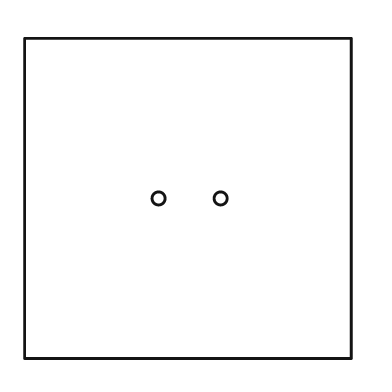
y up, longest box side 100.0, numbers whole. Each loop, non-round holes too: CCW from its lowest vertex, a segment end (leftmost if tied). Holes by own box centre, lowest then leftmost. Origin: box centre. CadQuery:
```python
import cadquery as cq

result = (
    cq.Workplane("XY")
    .moveTo(-50.0, -49.0)
    .lineTo(50.0, -49.0)
    .lineTo(50.0, 49.0)
    .lineTo(-50.0, 49.0)
    .close()
    .moveTo(-9.0, 0.0)
    .circle(2.0)
    .moveTo(10.0, 0.0)
    .circle(2.0)
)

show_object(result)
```